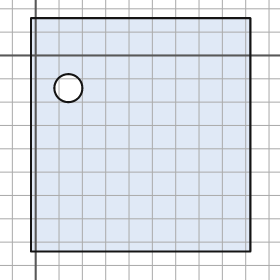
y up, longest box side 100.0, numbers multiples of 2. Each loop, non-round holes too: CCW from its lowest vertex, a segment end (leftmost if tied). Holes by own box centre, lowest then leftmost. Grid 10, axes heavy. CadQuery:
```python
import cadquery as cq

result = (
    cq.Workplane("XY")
    .moveTo(-2.0, -84.0)
    .lineTo(92.0, -84.0)
    .lineTo(92.0, 16.0)
    .lineTo(-2.0, 16.0)
    .close()
    .moveTo(14.0, -14.0)
    .circle(6.0)
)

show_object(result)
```